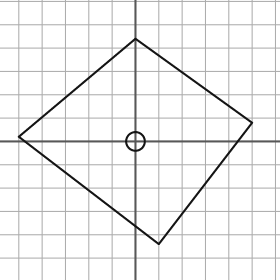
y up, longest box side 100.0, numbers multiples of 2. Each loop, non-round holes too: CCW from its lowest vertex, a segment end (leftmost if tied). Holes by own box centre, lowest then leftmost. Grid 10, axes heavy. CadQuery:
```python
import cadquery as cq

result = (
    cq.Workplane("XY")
    .moveTo(10.0, -44.0)
    .lineTo(50.0, 8.0)
    .lineTo(0.0, 44.0)
    .lineTo(-50.0, 2.0)
    .close()
    .moveTo(0.0, 0.0)
    .circle(4.0)
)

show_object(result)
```